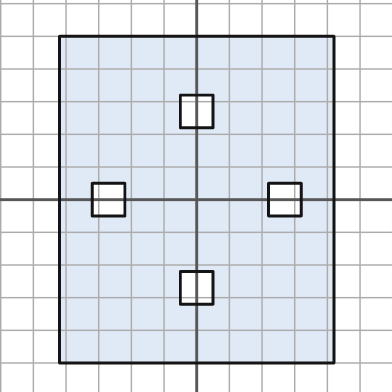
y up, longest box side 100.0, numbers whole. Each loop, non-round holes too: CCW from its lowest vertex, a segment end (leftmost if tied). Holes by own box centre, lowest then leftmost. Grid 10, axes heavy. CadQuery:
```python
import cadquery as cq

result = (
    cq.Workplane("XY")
    .moveTo(-42.0, -50.0)
    .lineTo(42.0, -50.0)
    .lineTo(42.0, 50.0)
    .lineTo(-42.0, 50.0)
    .close()
    .moveTo(-5.0, -32.0)
    .lineTo(5.0, -32.0)
    .lineTo(5.0, -22.0)
    .lineTo(-5.0, -22.0)
    .close()
    .moveTo(-32.0, -5.0)
    .lineTo(-22.0, -5.0)
    .lineTo(-22.0, 5.0)
    .lineTo(-32.0, 5.0)
    .close()
    .moveTo(22.0, -5.0)
    .lineTo(32.0, -5.0)
    .lineTo(32.0, 5.0)
    .lineTo(22.0, 5.0)
    .close()
    .moveTo(-5.0, 22.0)
    .lineTo(5.0, 22.0)
    .lineTo(5.0, 32.0)
    .lineTo(-5.0, 32.0)
    .close()
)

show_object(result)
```